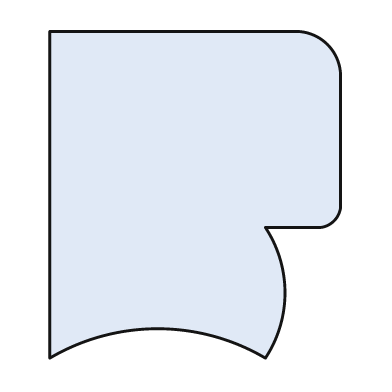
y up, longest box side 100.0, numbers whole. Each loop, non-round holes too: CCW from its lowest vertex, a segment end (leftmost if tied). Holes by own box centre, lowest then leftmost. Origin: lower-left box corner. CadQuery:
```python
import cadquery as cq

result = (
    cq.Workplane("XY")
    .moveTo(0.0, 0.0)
    .threePointArc((33.0, 9.0), (66.0, 0.0))
    .threePointArc((72.0, 20.0), (66.0, 40.0))
    .lineTo(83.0, 40.0)
    .threePointArc((87.0, 42.0), (89.0, 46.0))
    .lineTo(89.0, 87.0)
    .threePointArc((85.0, 96.0), (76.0, 100.0))
    .lineTo(0.0, 100.0)
    .close()
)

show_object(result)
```